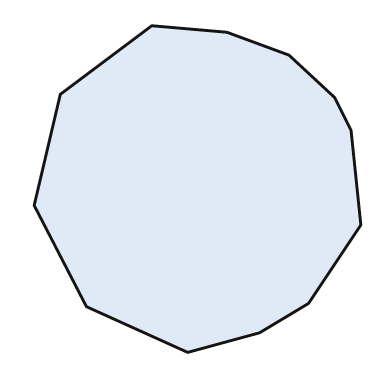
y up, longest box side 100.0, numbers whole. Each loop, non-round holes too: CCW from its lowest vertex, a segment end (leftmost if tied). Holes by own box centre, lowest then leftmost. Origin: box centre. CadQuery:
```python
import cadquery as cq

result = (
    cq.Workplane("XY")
    .moveTo(-3.0, -50.0)
    .lineTo(19.0, -44.0)
    .lineTo(34.0, -35.0)
    .lineTo(50.0, -11.0)
    .lineTo(47.0, 18.0)
    .lineTo(42.0, 28.0)
    .lineTo(28.0, 41.0)
    .lineTo(9.0, 48.0)
    .lineTo(-14.0, 50.0)
    .lineTo(-42.0, 29.0)
    .lineTo(-50.0, -5.0)
    .lineTo(-34.0, -36.0)
    .close()
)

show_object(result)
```